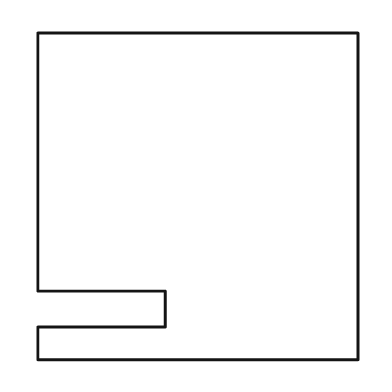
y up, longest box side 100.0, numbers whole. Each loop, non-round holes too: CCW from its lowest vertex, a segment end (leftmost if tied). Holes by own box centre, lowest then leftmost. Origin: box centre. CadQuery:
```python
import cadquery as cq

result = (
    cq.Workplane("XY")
    .moveTo(-49.0, -50.0)
    .lineTo(49.0, -50.0)
    .lineTo(49.0, 50.0)
    .lineTo(-49.0, 50.0)
    .lineTo(-49.0, -29.0)
    .lineTo(-10.0, -29.0)
    .lineTo(-10.0, -40.0)
    .lineTo(-49.0, -40.0)
    .close()
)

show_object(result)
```